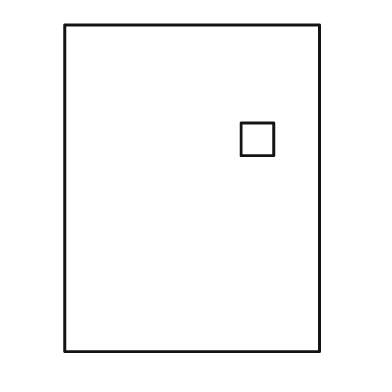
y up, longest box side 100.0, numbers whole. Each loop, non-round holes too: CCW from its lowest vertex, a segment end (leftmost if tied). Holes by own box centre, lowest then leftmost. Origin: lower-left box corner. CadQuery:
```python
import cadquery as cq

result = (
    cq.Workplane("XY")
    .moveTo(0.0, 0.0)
    .lineTo(78.0, 0.0)
    .lineTo(78.0, 100.0)
    .lineTo(0.0, 100.0)
    .close()
    .moveTo(54.0, 60.0)
    .lineTo(64.0, 60.0)
    .lineTo(64.0, 70.0)
    .lineTo(54.0, 70.0)
    .close()
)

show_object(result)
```